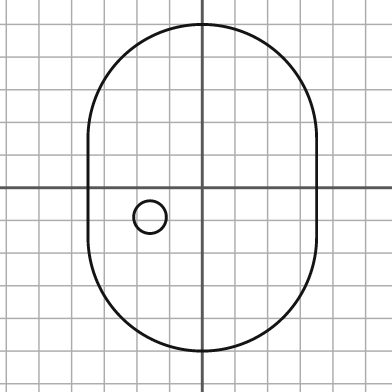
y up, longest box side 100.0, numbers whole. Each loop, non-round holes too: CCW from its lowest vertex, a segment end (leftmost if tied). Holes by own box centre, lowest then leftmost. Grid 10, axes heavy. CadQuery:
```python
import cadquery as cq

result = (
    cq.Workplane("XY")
    .moveTo(-35.0, -15.0)
    .threePointArc((0.0, -50.0), (35.0, -15.0))
    .lineTo(35.0, 15.0)
    .threePointArc((0.0, 50.0), (-35.0, 15.0))
    .close()
    .moveTo(-16.0, -9.0)
    .circle(5.0)
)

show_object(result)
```